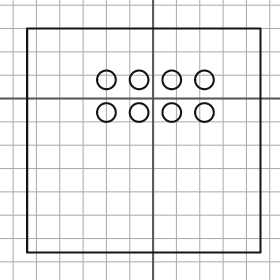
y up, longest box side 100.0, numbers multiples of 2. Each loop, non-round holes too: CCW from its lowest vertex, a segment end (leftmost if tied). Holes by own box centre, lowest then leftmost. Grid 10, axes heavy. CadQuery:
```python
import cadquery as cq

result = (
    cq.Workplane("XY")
    .moveTo(-54.0, -66.0)
    .lineTo(46.0, -66.0)
    .lineTo(46.0, 30.0)
    .lineTo(-54.0, 30.0)
    .close()
    .moveTo(-20.0, -6.0)
    .circle(4.0)
    .moveTo(-6.0, -6.0)
    .circle(4.0)
    .moveTo(8.0, -6.0)
    .circle(4.0)
    .moveTo(22.0, -6.0)
    .circle(4.0)
    .moveTo(-20.0, 8.0)
    .circle(4.0)
    .moveTo(-6.0, 8.0)
    .circle(4.0)
    .moveTo(8.0, 8.0)
    .circle(4.0)
    .moveTo(22.0, 8.0)
    .circle(4.0)
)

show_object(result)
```